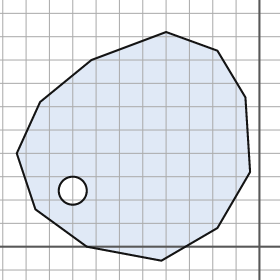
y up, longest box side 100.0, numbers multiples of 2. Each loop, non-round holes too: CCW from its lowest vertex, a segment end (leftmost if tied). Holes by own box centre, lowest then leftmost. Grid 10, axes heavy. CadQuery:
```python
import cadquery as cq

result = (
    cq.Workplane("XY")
    .moveTo(-42.0, -6.0)
    .lineTo(-18.0, 8.0)
    .lineTo(-4.0, 32.0)
    .lineTo(-6.0, 64.0)
    .lineTo(-18.0, 84.0)
    .lineTo(-40.0, 92.0)
    .lineTo(-72.0, 80.0)
    .lineTo(-94.0, 62.0)
    .lineTo(-104.0, 40.0)
    .lineTo(-96.0, 16.0)
    .lineTo(-74.0, 0.0)
    .close()
    .moveTo(-80.0, 24.0)
    .circle(6.0)
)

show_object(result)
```